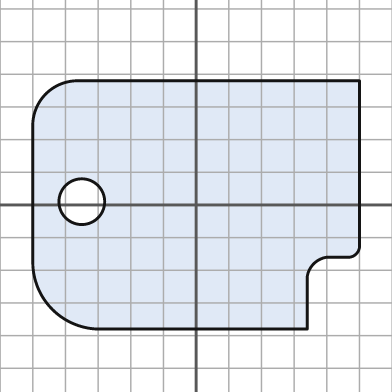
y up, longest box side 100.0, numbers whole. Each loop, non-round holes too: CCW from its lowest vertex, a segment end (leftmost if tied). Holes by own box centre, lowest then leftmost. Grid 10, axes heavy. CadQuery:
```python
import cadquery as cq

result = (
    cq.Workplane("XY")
    .moveTo(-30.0, -38.0)
    .lineTo(34.0, -38.0)
    .lineTo(34.0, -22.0)
    .threePointArc((36.0, -18.0), (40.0, -16.0))
    .lineTo(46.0, -16.0)
    .threePointArc((49.0, -15.0), (50.0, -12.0))
    .lineTo(50.0, 38.0)
    .lineTo(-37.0, 38.0)
    .threePointArc((-46.0, 34.0), (-50.0, 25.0))
    .lineTo(-50.0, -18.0)
    .threePointArc((-44.0, -32.0), (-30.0, -38.0))
    .close()
    .moveTo(-35.0, 1.0)
    .circle(7.0)
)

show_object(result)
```